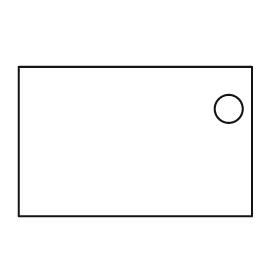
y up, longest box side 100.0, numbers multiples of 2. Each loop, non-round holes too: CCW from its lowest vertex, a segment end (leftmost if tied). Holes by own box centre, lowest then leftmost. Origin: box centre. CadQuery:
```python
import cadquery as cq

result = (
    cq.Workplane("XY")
    .moveTo(-50.0, -32.0)
    .lineTo(50.0, -32.0)
    .lineTo(50.0, 32.0)
    .lineTo(-50.0, 32.0)
    .close()
    .moveTo(40.0, 14.0)
    .circle(6.0)
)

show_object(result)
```